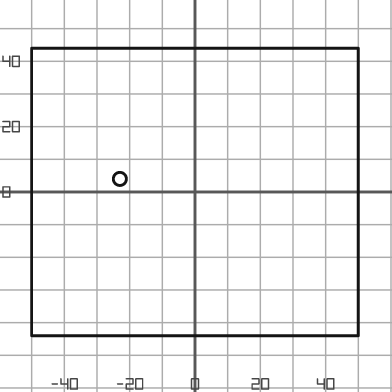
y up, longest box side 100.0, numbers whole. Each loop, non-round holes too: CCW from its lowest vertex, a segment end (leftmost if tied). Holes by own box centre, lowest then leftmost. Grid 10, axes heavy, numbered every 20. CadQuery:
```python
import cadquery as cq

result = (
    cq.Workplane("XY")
    .moveTo(-50.0, -44.0)
    .lineTo(50.0, -44.0)
    .lineTo(50.0, 44.0)
    .lineTo(-50.0, 44.0)
    .close()
    .moveTo(-23.0, 4.0)
    .circle(2.0)
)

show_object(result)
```